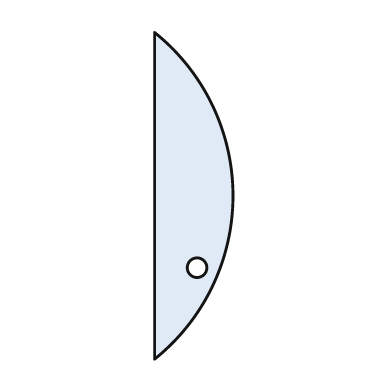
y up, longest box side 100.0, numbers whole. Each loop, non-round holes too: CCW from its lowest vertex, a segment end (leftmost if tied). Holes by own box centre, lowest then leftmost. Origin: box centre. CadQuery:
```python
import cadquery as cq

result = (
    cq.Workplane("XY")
    .moveTo(-12.0, -50.0)
    .threePointArc((12.0, 0.0), (-12.0, 50.0))
    .close()
    .moveTo(1.0, -22.0)
    .circle(3.0)
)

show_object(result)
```